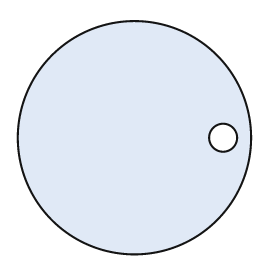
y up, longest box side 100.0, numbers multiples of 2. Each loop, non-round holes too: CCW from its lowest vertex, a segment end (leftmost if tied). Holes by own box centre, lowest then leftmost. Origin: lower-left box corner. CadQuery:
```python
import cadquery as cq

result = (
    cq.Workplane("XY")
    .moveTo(50.0, 50.0)
    .circle(50.0)
    .moveTo(88.0, 50.0)
    .circle(6.0)
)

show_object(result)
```